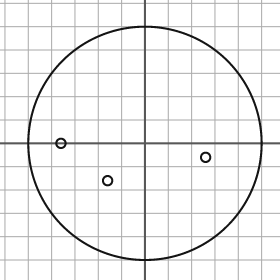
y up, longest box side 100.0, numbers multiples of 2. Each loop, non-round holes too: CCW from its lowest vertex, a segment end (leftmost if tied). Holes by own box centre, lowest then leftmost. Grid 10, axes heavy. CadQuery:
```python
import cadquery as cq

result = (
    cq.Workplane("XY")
    .moveTo(0.0, 0.0)
    .circle(50.0)
    .moveTo(-16.0, -16.0)
    .circle(2.0)
    .moveTo(26.0, -6.0)
    .circle(2.0)
    .moveTo(-36.0, 0.0)
    .circle(2.0)
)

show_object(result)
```